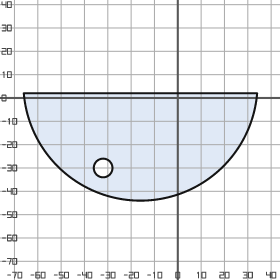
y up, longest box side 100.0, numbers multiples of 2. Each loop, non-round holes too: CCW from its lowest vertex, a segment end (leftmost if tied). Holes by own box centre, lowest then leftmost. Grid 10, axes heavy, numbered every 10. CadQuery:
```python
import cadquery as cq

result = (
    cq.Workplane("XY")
    .moveTo(-66.0, 2.0)
    .threePointArc((-16.0, -44.0), (34.0, 2.0))
    .close()
    .moveTo(-32.0, -30.0)
    .circle(4.0)
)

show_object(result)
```